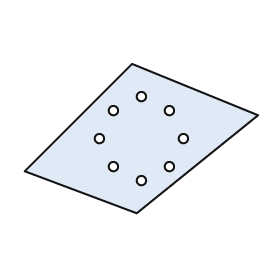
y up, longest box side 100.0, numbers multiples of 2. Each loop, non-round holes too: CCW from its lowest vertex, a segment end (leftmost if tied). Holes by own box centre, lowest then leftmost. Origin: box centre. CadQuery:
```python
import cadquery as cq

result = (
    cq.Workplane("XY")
    .moveTo(-2.0, -32.0)
    .lineTo(50.0, 10.0)
    .lineTo(-4.0, 32.0)
    .lineTo(-50.0, -14.0)
    .close()
    .moveTo(0.0, -18.0)
    .circle(2.0)
    .moveTo(-12.0, -12.0)
    .circle(2.0)
    .moveTo(12.0, -12.0)
    .circle(2.0)
    .moveTo(-18.0, 0.0)
    .circle(2.0)
    .moveTo(18.0, 0.0)
    .circle(2.0)
    .moveTo(-12.0, 12.0)
    .circle(2.0)
    .moveTo(12.0, 12.0)
    .circle(2.0)
    .moveTo(0.0, 18.0)
    .circle(2.0)
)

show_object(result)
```